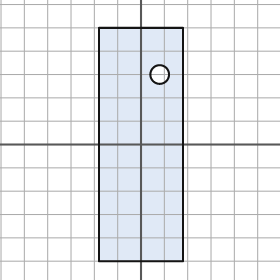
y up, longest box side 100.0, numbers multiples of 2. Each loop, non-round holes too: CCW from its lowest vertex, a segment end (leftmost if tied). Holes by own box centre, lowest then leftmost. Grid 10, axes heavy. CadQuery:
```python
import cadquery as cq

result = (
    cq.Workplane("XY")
    .moveTo(-18.0, -50.0)
    .lineTo(18.0, -50.0)
    .lineTo(18.0, 50.0)
    .lineTo(-18.0, 50.0)
    .close()
    .moveTo(8.0, 30.0)
    .circle(4.0)
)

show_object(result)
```